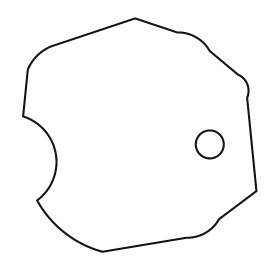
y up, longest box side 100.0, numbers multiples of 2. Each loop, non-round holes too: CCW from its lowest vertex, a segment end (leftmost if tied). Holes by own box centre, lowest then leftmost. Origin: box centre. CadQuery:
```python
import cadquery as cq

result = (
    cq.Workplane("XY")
    .moveTo(-16.0, -50.0)
    .lineTo(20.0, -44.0)
    .threePointArc((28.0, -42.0), (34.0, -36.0))
    .lineTo(50.0, -24.0)
    .lineTo(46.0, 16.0)
    .threePointArc((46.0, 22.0), (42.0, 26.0))
    .lineTo(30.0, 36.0)
    .threePointArc((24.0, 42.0), (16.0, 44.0))
    .lineTo(-2.0, 50.0)
    .lineTo(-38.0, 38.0)
    .threePointArc((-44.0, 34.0), (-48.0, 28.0))
    .lineTo(-50.0, 8.0)
    .threePointArc((-36.0, -8.0), (-44.0, -28.0))
    .threePointArc((-32.0, -42.0), (-16.0, -50.0))
    .close()
    .moveTo(30.0, -4.0)
    .circle(6.0)
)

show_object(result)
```